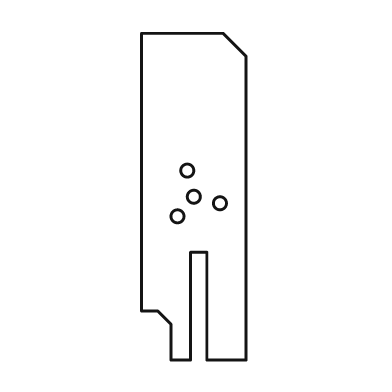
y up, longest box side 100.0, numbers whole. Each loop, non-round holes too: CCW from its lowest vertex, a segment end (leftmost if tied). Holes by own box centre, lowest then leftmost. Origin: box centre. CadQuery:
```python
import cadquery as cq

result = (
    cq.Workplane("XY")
    .moveTo(-7.0, -50.0)
    .lineTo(-1.0, -50.0)
    .lineTo(-1.0, -17.0)
    .lineTo(4.0, -17.0)
    .lineTo(4.0, -50.0)
    .lineTo(16.0, -50.0)
    .lineTo(16.0, 43.0)
    .lineTo(9.0, 50.0)
    .lineTo(-16.0, 50.0)
    .lineTo(-16.0, -35.0)
    .lineTo(-11.0, -35.0)
    .lineTo(-7.0, -39.0)
    .close()
    .moveTo(-5.0, -6.0)
    .circle(2.0)
    .moveTo(8.0, -2.0)
    .circle(2.0)
    .moveTo(0.0, 0.0)
    .circle(2.0)
    .moveTo(-2.0, 8.0)
    .circle(2.0)
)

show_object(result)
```